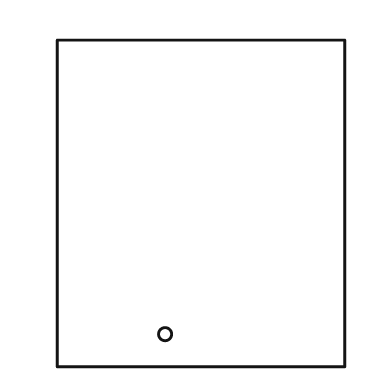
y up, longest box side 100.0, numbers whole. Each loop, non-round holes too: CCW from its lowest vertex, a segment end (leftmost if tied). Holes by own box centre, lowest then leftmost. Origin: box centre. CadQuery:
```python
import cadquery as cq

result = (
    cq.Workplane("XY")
    .moveTo(-44.0, -50.0)
    .lineTo(44.0, -50.0)
    .lineTo(44.0, 50.0)
    .lineTo(-44.0, 50.0)
    .close()
    .moveTo(-11.0, -40.0)
    .circle(2.0)
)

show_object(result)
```